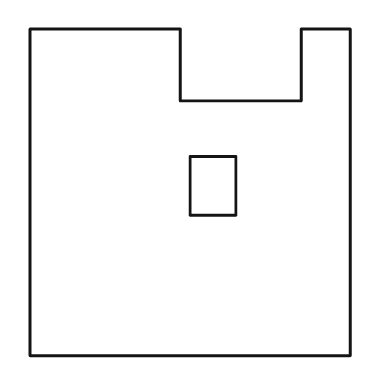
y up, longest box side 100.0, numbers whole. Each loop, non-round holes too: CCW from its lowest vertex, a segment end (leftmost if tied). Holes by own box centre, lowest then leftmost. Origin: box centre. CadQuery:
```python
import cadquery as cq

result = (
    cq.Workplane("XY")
    .moveTo(-49.0, -50.0)
    .lineTo(49.0, -50.0)
    .lineTo(49.0, 50.0)
    .lineTo(34.0, 50.0)
    .lineTo(34.0, 28.0)
    .lineTo(-3.0, 28.0)
    .lineTo(-3.0, 50.0)
    .lineTo(-49.0, 50.0)
    .close()
    .moveTo(0.0, -7.0)
    .lineTo(14.0, -7.0)
    .lineTo(14.0, 11.0)
    .lineTo(0.0, 11.0)
    .close()
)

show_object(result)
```